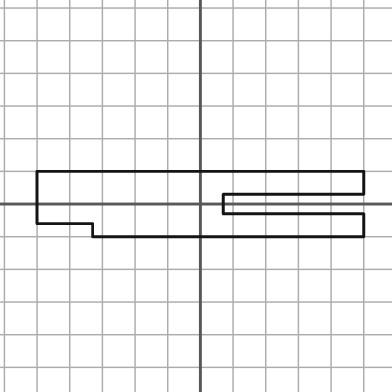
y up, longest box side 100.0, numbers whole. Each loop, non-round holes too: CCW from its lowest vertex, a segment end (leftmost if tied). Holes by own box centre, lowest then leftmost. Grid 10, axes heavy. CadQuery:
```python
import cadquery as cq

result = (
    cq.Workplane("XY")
    .moveTo(-33.0, -10.0)
    .lineTo(50.0, -10.0)
    .lineTo(50.0, -3.0)
    .lineTo(7.0, -3.0)
    .lineTo(7.0, 3.0)
    .lineTo(50.0, 3.0)
    .lineTo(50.0, 10.0)
    .lineTo(-50.0, 10.0)
    .lineTo(-50.0, -6.0)
    .lineTo(-33.0, -6.0)
    .close()
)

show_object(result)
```